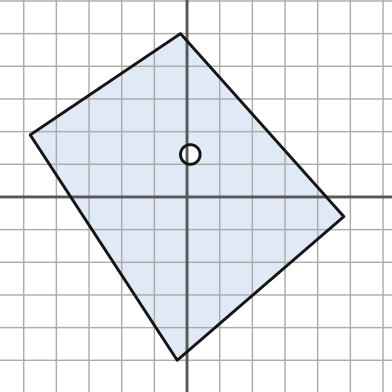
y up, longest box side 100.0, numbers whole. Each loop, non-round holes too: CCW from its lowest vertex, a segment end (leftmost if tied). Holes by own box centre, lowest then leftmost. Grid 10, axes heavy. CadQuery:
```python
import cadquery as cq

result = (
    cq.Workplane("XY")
    .moveTo(-3.0, -50.0)
    .lineTo(48.0, -6.0)
    .lineTo(-2.0, 50.0)
    .lineTo(-48.0, 19.0)
    .close()
    .moveTo(1.0, 13.0)
    .circle(3.0)
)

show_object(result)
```